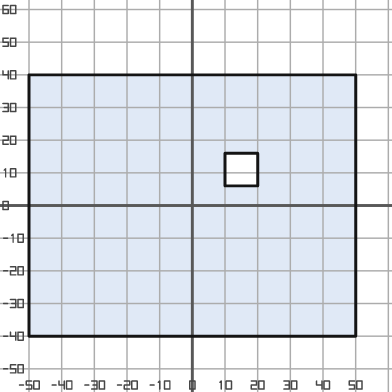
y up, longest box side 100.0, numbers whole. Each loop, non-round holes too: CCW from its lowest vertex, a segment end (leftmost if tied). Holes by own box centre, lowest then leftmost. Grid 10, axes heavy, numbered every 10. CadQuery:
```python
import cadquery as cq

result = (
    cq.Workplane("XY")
    .moveTo(-50.0, -40.0)
    .lineTo(50.0, -40.0)
    .lineTo(50.0, 40.0)
    .lineTo(-50.0, 40.0)
    .close()
    .moveTo(10.0, 6.0)
    .lineTo(20.0, 6.0)
    .lineTo(20.0, 16.0)
    .lineTo(10.0, 16.0)
    .close()
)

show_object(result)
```